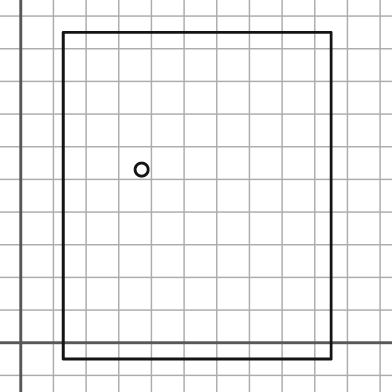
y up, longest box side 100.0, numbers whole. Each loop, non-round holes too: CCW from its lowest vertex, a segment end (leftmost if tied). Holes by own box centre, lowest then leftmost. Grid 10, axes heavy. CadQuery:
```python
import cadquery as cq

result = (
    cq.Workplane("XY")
    .moveTo(13.0, -5.0)
    .lineTo(95.0, -5.0)
    .lineTo(95.0, 95.0)
    .lineTo(13.0, 95.0)
    .close()
    .moveTo(37.0, 53.0)
    .circle(2.0)
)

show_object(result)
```